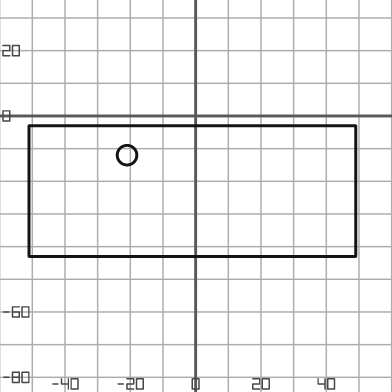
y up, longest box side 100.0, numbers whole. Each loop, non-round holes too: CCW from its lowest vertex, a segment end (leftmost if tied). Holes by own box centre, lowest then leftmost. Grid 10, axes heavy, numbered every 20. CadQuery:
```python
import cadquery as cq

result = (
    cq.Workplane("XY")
    .moveTo(-51.0, -43.0)
    .lineTo(49.0, -43.0)
    .lineTo(49.0, -3.0)
    .lineTo(-51.0, -3.0)
    .close()
    .moveTo(-21.0, -12.0)
    .circle(3.0)
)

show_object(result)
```